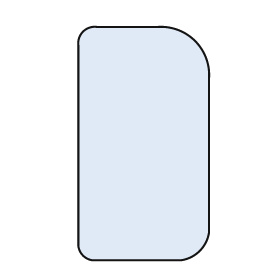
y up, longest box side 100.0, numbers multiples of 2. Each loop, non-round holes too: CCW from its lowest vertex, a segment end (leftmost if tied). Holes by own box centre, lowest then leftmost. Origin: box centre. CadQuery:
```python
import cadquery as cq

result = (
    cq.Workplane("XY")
    .moveTo(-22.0, -50.0)
    .lineTo(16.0, -50.0)
    .threePointArc((24.0, -46.0), (28.0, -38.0))
    .lineTo(28.0, 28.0)
    .threePointArc((22.0, 44.0), (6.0, 50.0))
    .lineTo(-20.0, 50.0)
    .threePointArc((-26.0, 48.0), (-28.0, 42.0))
    .lineTo(-28.0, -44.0)
    .threePointArc((-26.0, -48.0), (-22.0, -50.0))
    .close()
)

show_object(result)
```